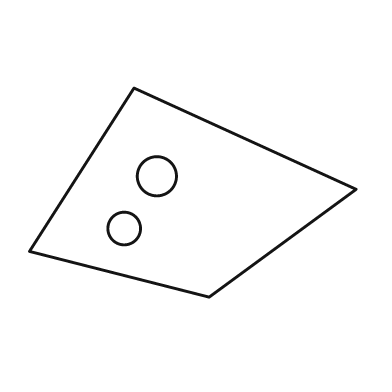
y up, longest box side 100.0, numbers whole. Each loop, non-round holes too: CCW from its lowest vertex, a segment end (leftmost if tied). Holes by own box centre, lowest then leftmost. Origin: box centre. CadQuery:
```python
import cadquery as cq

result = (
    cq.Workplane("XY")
    .moveTo(5.0, -32.0)
    .lineTo(50.0, 1.0)
    .lineTo(-18.0, 32.0)
    .lineTo(-50.0, -18.0)
    .close()
    .moveTo(-21.0, -11.0)
    .circle(5.0)
    .moveTo(-11.0, 5.0)
    .circle(6.0)
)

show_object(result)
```